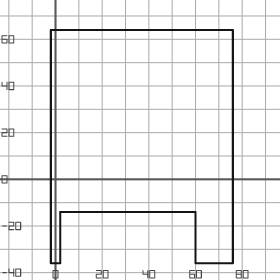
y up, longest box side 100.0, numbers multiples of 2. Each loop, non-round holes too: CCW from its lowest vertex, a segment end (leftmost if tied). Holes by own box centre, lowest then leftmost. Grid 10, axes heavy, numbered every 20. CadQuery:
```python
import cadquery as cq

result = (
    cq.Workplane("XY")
    .moveTo(-2.0, -36.0)
    .lineTo(2.0, -36.0)
    .lineTo(2.0, -14.0)
    .lineTo(60.0, -14.0)
    .lineTo(60.0, -36.0)
    .lineTo(76.0, -36.0)
    .lineTo(76.0, 64.0)
    .lineTo(-2.0, 64.0)
    .close()
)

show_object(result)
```